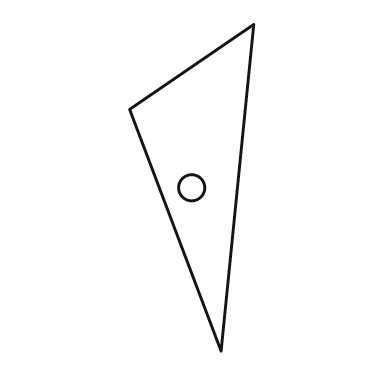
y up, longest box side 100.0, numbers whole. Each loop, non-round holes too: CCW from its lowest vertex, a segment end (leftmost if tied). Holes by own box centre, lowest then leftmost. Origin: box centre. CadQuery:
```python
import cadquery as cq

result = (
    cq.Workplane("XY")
    .moveTo(9.0, -50.0)
    .lineTo(19.0, 50.0)
    .lineTo(-19.0, 24.0)
    .close()
    .moveTo(0.0, 0.0)
    .circle(4.0)
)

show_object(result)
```